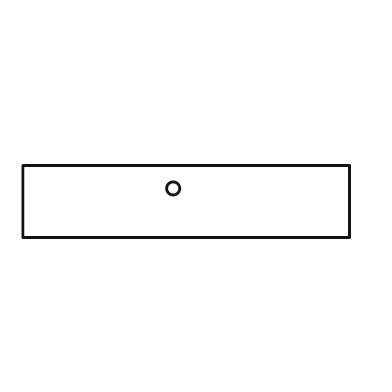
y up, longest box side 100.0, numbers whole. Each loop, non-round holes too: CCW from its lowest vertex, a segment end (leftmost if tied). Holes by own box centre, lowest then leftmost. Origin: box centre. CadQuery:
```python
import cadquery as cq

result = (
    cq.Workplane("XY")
    .moveTo(-50.0, -11.0)
    .lineTo(50.0, -11.0)
    .lineTo(50.0, 11.0)
    .lineTo(-50.0, 11.0)
    .close()
    .moveTo(-4.0, 4.0)
    .circle(2.0)
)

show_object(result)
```